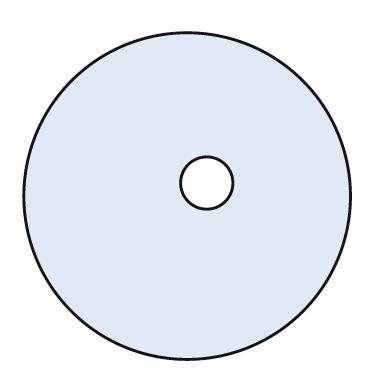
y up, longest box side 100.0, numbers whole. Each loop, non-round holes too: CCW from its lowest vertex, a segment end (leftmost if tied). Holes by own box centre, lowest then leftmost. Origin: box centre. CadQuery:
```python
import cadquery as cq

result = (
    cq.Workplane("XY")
    .moveTo(0.0, 0.0)
    .circle(50.0)
    .moveTo(6.0, 4.0)
    .circle(8.0)
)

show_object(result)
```